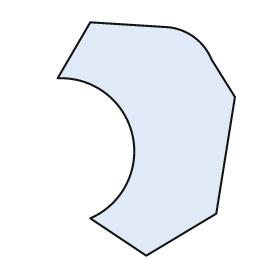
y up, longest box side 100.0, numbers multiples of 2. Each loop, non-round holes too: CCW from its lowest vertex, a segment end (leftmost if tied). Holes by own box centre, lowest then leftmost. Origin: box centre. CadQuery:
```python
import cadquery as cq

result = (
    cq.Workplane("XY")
    .moveTo(0.0, -50.0)
    .lineTo(30.0, -32.0)
    .lineTo(38.0, 18.0)
    .lineTo(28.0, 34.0)
    .threePointArc((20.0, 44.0), (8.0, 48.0))
    .lineTo(-24.0, 50.0)
    .lineTo(-38.0, 26.0)
    .threePointArc((-6.0, 2.0), (-24.0, -34.0))
    .close()
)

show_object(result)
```